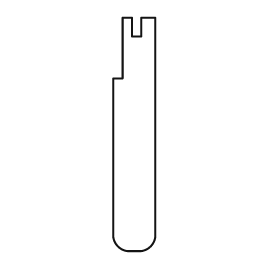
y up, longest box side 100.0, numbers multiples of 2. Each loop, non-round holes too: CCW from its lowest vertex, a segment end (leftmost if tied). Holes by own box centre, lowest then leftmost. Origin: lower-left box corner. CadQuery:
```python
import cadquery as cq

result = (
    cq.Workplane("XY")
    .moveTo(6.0, 0.0)
    .lineTo(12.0, 0.0)
    .threePointArc((16.0, 2.0), (18.0, 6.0))
    .lineTo(18.0, 100.0)
    .lineTo(12.0, 100.0)
    .lineTo(12.0, 92.0)
    .lineTo(8.0, 92.0)
    .lineTo(8.0, 100.0)
    .lineTo(4.0, 100.0)
    .lineTo(4.0, 74.0)
    .lineTo(0.0, 74.0)
    .lineTo(0.0, 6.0)
    .threePointArc((2.0, 2.0), (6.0, 0.0))
    .close()
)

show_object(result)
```